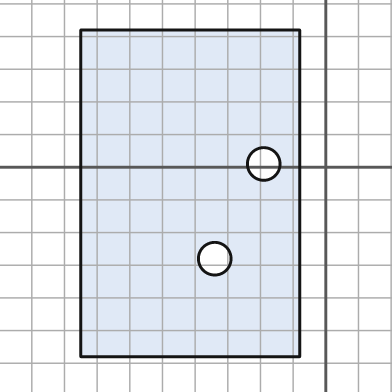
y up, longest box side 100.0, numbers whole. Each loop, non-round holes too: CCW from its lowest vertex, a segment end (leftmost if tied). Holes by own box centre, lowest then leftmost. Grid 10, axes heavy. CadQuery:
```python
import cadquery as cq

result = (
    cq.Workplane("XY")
    .moveTo(-75.0, -58.0)
    .lineTo(-8.0, -58.0)
    .lineTo(-8.0, 42.0)
    .lineTo(-75.0, 42.0)
    .close()
    .moveTo(-34.0, -28.0)
    .circle(5.0)
    .moveTo(-19.0, 1.0)
    .circle(5.0)
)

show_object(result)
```